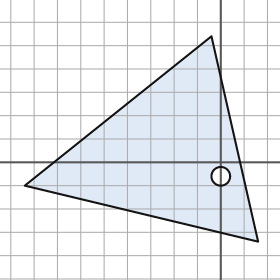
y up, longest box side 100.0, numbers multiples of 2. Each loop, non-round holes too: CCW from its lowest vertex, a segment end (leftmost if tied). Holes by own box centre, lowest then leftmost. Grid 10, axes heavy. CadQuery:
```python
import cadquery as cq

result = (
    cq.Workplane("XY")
    .moveTo(16.0, -34.0)
    .lineTo(-4.0, 54.0)
    .lineTo(-84.0, -10.0)
    .close()
    .moveTo(0.0, -6.0)
    .circle(4.0)
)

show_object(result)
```